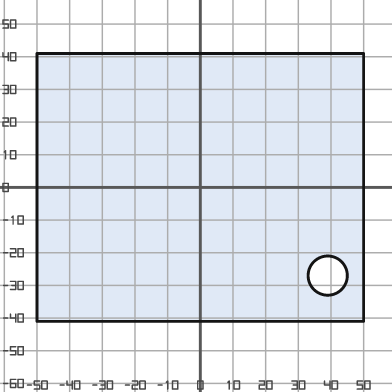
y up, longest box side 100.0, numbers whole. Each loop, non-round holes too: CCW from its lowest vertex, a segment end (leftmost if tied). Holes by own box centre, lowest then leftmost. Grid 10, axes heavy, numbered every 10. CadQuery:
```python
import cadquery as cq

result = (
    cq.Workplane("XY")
    .moveTo(-50.0, -41.0)
    .lineTo(50.0, -41.0)
    .lineTo(50.0, 41.0)
    .lineTo(-50.0, 41.0)
    .close()
    .moveTo(39.0, -27.0)
    .circle(6.0)
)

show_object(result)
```